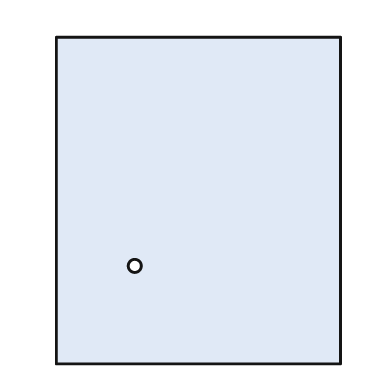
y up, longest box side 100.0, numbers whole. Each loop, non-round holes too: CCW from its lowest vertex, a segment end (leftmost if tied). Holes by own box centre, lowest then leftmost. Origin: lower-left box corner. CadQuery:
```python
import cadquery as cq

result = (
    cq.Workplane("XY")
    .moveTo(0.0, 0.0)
    .lineTo(87.0, 0.0)
    .lineTo(87.0, 100.0)
    .lineTo(0.0, 100.0)
    .close()
    .moveTo(24.0, 30.0)
    .circle(2.0)
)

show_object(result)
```